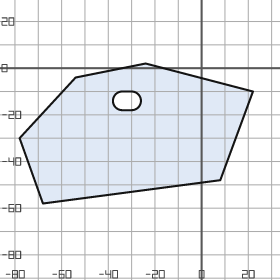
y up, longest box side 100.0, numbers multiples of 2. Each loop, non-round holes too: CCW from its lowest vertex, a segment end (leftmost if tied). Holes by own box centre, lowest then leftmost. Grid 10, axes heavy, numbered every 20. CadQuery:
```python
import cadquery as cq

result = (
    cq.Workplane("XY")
    .moveTo(-68.0, -58.0)
    .lineTo(8.0, -48.0)
    .lineTo(22.0, -10.0)
    .lineTo(-24.0, 2.0)
    .lineTo(-54.0, -4.0)
    .lineTo(-78.0, -30.0)
    .close()
    .moveTo(-34.0, -18.0)
    .lineTo(-30.0, -18.0)
    .threePointArc((-26.0, -14.0), (-30.0, -10.0))
    .lineTo(-34.0, -10.0)
    .threePointArc((-38.0, -14.0), (-34.0, -18.0))
    .close()
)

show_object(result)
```